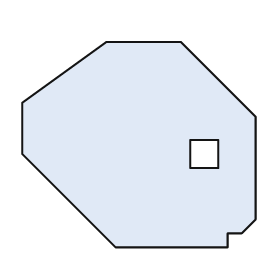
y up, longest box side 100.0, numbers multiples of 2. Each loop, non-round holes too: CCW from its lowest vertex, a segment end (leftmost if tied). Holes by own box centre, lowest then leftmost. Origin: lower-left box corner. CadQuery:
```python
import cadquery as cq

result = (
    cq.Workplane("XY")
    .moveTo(40.0, 0.0)
    .lineTo(88.0, 0.0)
    .lineTo(88.0, 6.0)
    .lineTo(94.0, 6.0)
    .lineTo(100.0, 12.0)
    .lineTo(100.0, 56.0)
    .lineTo(68.0, 88.0)
    .lineTo(36.0, 88.0)
    .lineTo(0.0, 62.0)
    .lineTo(0.0, 40.0)
    .close()
    .moveTo(72.0, 34.0)
    .lineTo(84.0, 34.0)
    .lineTo(84.0, 46.0)
    .lineTo(72.0, 46.0)
    .close()
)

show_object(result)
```